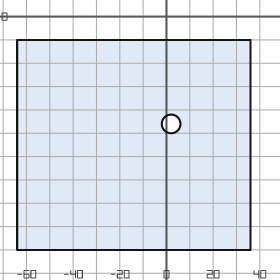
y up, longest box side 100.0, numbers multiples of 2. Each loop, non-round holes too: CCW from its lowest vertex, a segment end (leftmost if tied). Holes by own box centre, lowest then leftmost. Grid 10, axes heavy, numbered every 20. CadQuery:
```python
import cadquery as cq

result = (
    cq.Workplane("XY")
    .moveTo(-64.0, -100.0)
    .lineTo(36.0, -100.0)
    .lineTo(36.0, -10.0)
    .lineTo(-64.0, -10.0)
    .close()
    .moveTo(2.0, -46.0)
    .circle(4.0)
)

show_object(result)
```